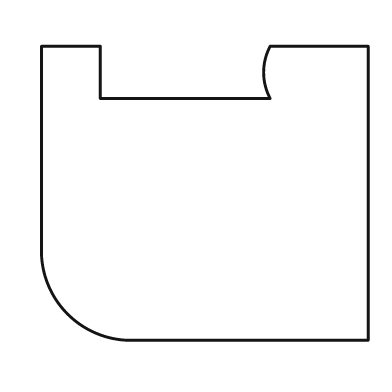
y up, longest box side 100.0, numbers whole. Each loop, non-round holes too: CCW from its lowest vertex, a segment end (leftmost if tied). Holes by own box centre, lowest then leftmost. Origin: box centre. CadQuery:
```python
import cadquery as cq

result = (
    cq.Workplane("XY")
    .moveTo(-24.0, -45.0)
    .lineTo(50.0, -45.0)
    .lineTo(50.0, 45.0)
    .lineTo(20.0, 45.0)
    .threePointArc((18.0, 37.0), (20.0, 29.0))
    .lineTo(-32.0, 29.0)
    .lineTo(-32.0, 45.0)
    .lineTo(-50.0, 45.0)
    .lineTo(-50.0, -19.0)
    .threePointArc((-42.0, -37.0), (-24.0, -45.0))
    .close()
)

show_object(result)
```